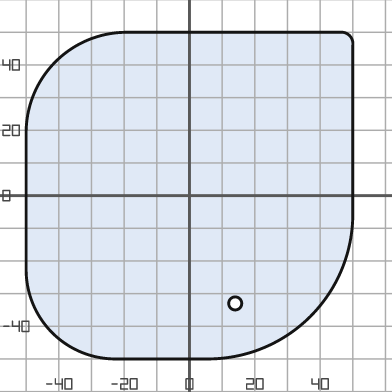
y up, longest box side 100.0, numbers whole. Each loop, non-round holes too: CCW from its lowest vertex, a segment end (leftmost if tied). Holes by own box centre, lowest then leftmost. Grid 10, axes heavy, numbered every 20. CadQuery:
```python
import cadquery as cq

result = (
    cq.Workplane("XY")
    .moveTo(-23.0, -50.0)
    .lineTo(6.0, -50.0)
    .threePointArc((37.0, -37.0), (50.0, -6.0))
    .lineTo(50.0, 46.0)
    .threePointArc((49.0, 49.0), (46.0, 50.0))
    .lineTo(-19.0, 50.0)
    .threePointArc((-41.0, 41.0), (-50.0, 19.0))
    .lineTo(-50.0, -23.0)
    .threePointArc((-42.0, -42.0), (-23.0, -50.0))
    .close()
    .moveTo(14.0, -33.0)
    .circle(2.0)
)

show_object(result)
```